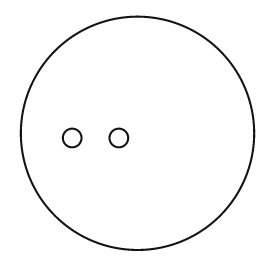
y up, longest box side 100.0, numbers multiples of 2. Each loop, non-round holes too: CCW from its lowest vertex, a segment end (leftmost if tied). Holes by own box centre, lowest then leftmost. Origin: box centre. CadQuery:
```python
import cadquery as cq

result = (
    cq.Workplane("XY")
    .moveTo(0.0, 0.0)
    .circle(50.0)
    .moveTo(-28.0, -2.0)
    .circle(4.0)
    .moveTo(-8.0, -2.0)
    .circle(4.0)
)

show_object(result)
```